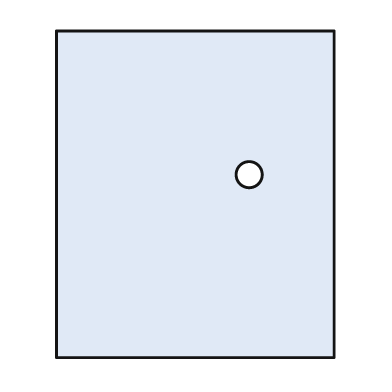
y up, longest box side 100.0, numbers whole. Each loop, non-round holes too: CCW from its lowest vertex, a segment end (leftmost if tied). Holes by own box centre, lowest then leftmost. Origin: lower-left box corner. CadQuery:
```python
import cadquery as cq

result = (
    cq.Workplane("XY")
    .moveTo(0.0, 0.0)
    .lineTo(85.0, 0.0)
    .lineTo(85.0, 100.0)
    .lineTo(0.0, 100.0)
    .close()
    .moveTo(59.0, 56.0)
    .circle(4.0)
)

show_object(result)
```